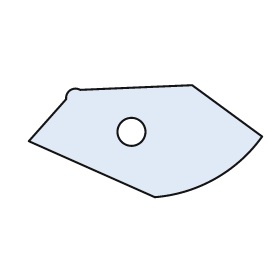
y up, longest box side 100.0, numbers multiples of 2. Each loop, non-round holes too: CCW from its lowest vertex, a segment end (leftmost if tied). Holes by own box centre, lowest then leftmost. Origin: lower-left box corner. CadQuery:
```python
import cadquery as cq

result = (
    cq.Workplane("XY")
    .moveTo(54.0, 0.0)
    .threePointArc((80.0, 8.0), (100.0, 26.0))
    .lineTo(70.0, 48.0)
    .lineTo(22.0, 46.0)
    .threePointArc((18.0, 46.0), (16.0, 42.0))
    .lineTo(0.0, 24.0)
    .close()
    .moveTo(44.0, 28.0)
    .circle(6.0)
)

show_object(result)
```